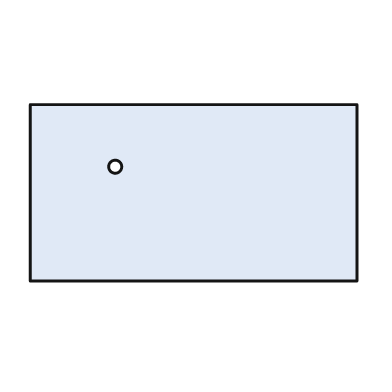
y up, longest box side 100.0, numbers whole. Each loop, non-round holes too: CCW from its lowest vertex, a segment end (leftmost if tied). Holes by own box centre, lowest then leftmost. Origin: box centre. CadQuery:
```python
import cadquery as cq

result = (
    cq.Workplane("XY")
    .moveTo(-50.0, -27.0)
    .lineTo(50.0, -27.0)
    .lineTo(50.0, 27.0)
    .lineTo(-50.0, 27.0)
    .close()
    .moveTo(-24.0, 8.0)
    .circle(2.0)
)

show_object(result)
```